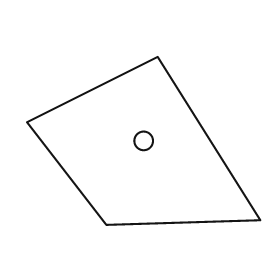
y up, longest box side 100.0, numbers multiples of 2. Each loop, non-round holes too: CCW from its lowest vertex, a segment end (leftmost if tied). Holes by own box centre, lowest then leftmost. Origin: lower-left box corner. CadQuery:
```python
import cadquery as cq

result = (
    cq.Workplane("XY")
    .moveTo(34.0, 0.0)
    .lineTo(100.0, 2.0)
    .lineTo(56.0, 72.0)
    .lineTo(0.0, 44.0)
    .close()
    .moveTo(50.0, 36.0)
    .circle(4.0)
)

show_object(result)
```